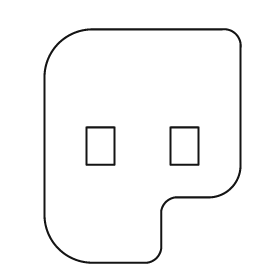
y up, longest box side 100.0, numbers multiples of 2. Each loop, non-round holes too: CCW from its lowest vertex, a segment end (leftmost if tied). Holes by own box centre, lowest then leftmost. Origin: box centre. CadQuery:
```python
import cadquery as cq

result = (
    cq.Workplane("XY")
    .moveTo(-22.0, -50.0)
    .lineTo(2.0, -50.0)
    .threePointArc((6.0, -48.0), (8.0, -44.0))
    .lineTo(8.0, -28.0)
    .threePointArc((10.0, -24.0), (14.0, -22.0))
    .lineTo(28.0, -22.0)
    .threePointArc((38.0, -18.0), (42.0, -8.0))
    .lineTo(42.0, 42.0)
    .threePointArc((40.0, 48.0), (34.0, 50.0))
    .lineTo(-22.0, 50.0)
    .threePointArc((-36.0, 44.0), (-42.0, 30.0))
    .lineTo(-42.0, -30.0)
    .threePointArc((-36.0, -44.0), (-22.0, -50.0))
    .close()
    .moveTo(-24.0, -8.0)
    .lineTo(-12.0, -8.0)
    .lineTo(-12.0, 8.0)
    .lineTo(-24.0, 8.0)
    .close()
    .moveTo(12.0, -8.0)
    .lineTo(24.0, -8.0)
    .lineTo(24.0, 8.0)
    .lineTo(12.0, 8.0)
    .close()
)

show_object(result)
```